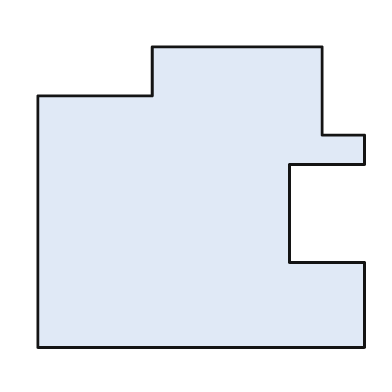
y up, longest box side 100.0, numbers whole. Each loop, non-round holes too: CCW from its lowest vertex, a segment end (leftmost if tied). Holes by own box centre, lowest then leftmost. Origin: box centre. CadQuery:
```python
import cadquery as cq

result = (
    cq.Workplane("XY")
    .moveTo(-50.0, -46.0)
    .lineTo(50.0, -46.0)
    .lineTo(50.0, -20.0)
    .lineTo(27.0, -20.0)
    .lineTo(27.0, 10.0)
    .lineTo(50.0, 10.0)
    .lineTo(50.0, 19.0)
    .lineTo(37.0, 19.0)
    .lineTo(37.0, 46.0)
    .lineTo(-15.0, 46.0)
    .lineTo(-15.0, 31.0)
    .lineTo(-50.0, 31.0)
    .close()
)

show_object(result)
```